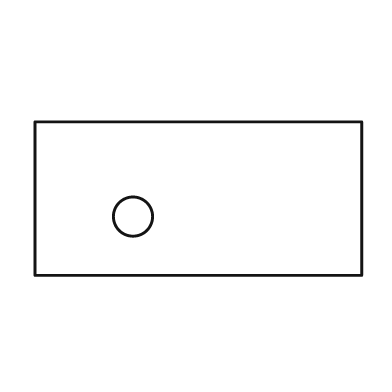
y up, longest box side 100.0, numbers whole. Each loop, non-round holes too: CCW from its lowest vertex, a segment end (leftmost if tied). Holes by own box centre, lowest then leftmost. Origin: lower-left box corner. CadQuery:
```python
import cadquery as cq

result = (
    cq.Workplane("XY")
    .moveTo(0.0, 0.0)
    .lineTo(100.0, 0.0)
    .lineTo(100.0, 47.0)
    .lineTo(0.0, 47.0)
    .close()
    .moveTo(30.0, 18.0)
    .circle(6.0)
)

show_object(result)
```